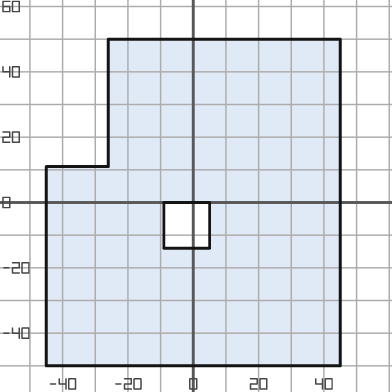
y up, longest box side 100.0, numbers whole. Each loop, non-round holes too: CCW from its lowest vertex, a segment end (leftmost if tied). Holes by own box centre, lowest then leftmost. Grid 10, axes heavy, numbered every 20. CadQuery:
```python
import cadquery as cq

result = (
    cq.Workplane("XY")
    .moveTo(-45.0, -50.0)
    .lineTo(45.0, -50.0)
    .lineTo(45.0, 50.0)
    .lineTo(-26.0, 50.0)
    .lineTo(-26.0, 11.0)
    .lineTo(-45.0, 11.0)
    .close()
    .moveTo(-9.0, -14.0)
    .lineTo(5.0, -14.0)
    .lineTo(5.0, 0.0)
    .lineTo(-9.0, 0.0)
    .close()
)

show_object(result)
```